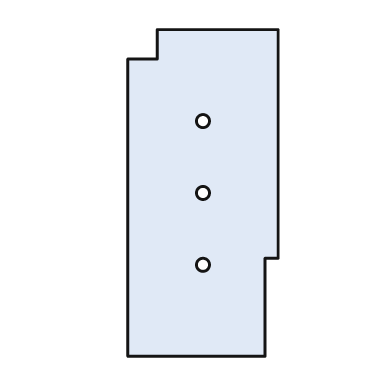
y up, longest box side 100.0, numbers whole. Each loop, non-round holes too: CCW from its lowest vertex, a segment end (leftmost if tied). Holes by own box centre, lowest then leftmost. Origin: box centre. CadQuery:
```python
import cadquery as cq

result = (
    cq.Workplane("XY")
    .moveTo(-23.0, -50.0)
    .lineTo(19.0, -50.0)
    .lineTo(19.0, -20.0)
    .lineTo(23.0, -20.0)
    .lineTo(23.0, 50.0)
    .lineTo(-14.0, 50.0)
    .lineTo(-14.0, 41.0)
    .lineTo(-23.0, 41.0)
    .close()
    .moveTo(0.0, -22.0)
    .circle(2.0)
    .moveTo(0.0, 0.0)
    .circle(2.0)
    .moveTo(0.0, 22.0)
    .circle(2.0)
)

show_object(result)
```